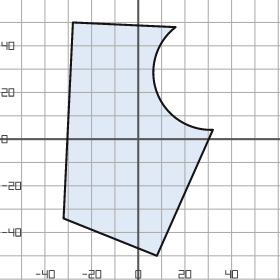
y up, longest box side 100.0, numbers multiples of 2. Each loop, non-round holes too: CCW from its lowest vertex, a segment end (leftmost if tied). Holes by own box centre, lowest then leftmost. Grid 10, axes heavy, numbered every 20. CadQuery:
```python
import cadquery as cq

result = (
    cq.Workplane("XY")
    .moveTo(8.0, -50.0)
    .lineTo(32.0, 4.0)
    .threePointArc((8.0, 20.0), (16.0, 48.0))
    .lineTo(-28.0, 50.0)
    .lineTo(-32.0, -34.0)
    .close()
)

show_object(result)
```